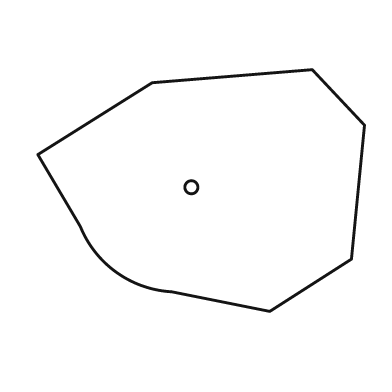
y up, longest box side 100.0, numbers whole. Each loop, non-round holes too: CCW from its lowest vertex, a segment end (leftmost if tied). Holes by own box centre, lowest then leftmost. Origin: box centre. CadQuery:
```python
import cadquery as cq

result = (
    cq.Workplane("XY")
    .moveTo(21.0, -37.0)
    .lineTo(46.0, -21.0)
    .lineTo(50.0, 20.0)
    .lineTo(34.0, 37.0)
    .lineTo(-15.0, 33.0)
    .lineTo(-50.0, 11.0)
    .lineTo(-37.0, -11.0)
    .threePointArc((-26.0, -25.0), (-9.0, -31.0))
    .close()
    .moveTo(-3.0, 1.0)
    .circle(2.0)
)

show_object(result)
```